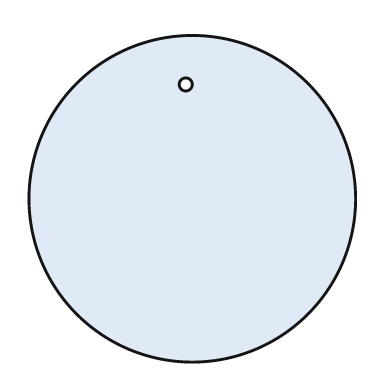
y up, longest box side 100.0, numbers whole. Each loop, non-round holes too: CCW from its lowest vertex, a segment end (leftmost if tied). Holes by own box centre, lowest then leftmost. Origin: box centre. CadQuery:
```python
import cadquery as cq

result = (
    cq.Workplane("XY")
    .moveTo(0.0, 0.0)
    .circle(50.0)
    .moveTo(-2.0, 35.0)
    .circle(2.0)
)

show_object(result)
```